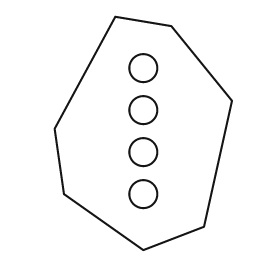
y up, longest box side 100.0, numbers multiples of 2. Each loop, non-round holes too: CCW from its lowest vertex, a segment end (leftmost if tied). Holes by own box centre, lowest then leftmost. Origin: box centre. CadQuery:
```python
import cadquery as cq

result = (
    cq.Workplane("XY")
    .moveTo(0.0, -50.0)
    .lineTo(26.0, -40.0)
    .lineTo(38.0, 14.0)
    .lineTo(12.0, 46.0)
    .lineTo(-12.0, 50.0)
    .lineTo(-38.0, 2.0)
    .lineTo(-34.0, -26.0)
    .close()
    .moveTo(0.0, -26.0)
    .circle(6.0)
    .moveTo(0.0, -8.0)
    .circle(6.0)
    .moveTo(0.0, 10.0)
    .circle(6.0)
    .moveTo(0.0, 28.0)
    .circle(6.0)
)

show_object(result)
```